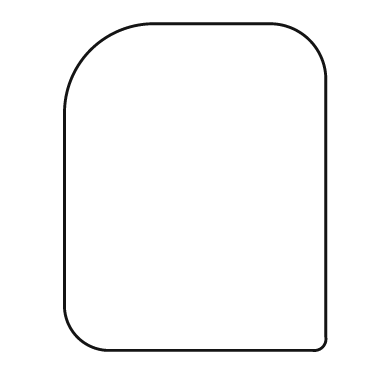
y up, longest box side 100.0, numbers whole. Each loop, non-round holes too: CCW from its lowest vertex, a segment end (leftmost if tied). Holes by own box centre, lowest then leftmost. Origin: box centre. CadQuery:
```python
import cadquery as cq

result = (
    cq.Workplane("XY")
    .moveTo(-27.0, -50.0)
    .lineTo(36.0, -50.0)
    .threePointArc((39.0, -49.0), (40.0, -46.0))
    .lineTo(40.0, 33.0)
    .threePointArc((35.0, 45.0), (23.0, 50.0))
    .lineTo(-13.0, 50.0)
    .threePointArc((-32.0, 42.0), (-40.0, 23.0))
    .lineTo(-40.0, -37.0)
    .threePointArc((-36.0, -46.0), (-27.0, -50.0))
    .close()
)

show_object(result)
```